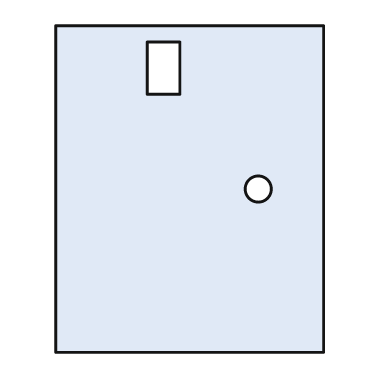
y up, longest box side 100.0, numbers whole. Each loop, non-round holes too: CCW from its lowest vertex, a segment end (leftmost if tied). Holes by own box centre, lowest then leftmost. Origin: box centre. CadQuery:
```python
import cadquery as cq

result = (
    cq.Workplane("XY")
    .moveTo(-41.0, -50.0)
    .lineTo(41.0, -50.0)
    .lineTo(41.0, 50.0)
    .lineTo(-41.0, 50.0)
    .close()
    .moveTo(21.0, 0.0)
    .circle(4.0)
    .moveTo(-13.0, 29.0)
    .lineTo(-3.0, 29.0)
    .lineTo(-3.0, 45.0)
    .lineTo(-13.0, 45.0)
    .close()
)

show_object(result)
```